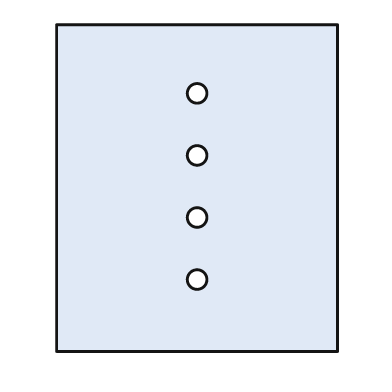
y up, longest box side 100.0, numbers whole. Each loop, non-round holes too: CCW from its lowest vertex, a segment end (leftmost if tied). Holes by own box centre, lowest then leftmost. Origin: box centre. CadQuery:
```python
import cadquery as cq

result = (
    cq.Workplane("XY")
    .moveTo(-43.0, -50.0)
    .lineTo(43.0, -50.0)
    .lineTo(43.0, 50.0)
    .lineTo(-43.0, 50.0)
    .close()
    .moveTo(0.0, -28.0)
    .circle(3.0)
    .moveTo(0.0, -9.0)
    .circle(3.0)
    .moveTo(0.0, 10.0)
    .circle(3.0)
    .moveTo(0.0, 29.0)
    .circle(3.0)
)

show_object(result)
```